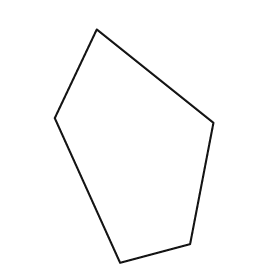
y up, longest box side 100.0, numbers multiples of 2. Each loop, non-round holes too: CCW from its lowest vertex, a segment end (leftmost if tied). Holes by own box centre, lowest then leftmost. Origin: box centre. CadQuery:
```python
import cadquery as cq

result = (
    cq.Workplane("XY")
    .moveTo(-6.0, -50.0)
    .lineTo(24.0, -42.0)
    .lineTo(34.0, 10.0)
    .lineTo(-16.0, 50.0)
    .lineTo(-34.0, 12.0)
    .close()
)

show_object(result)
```